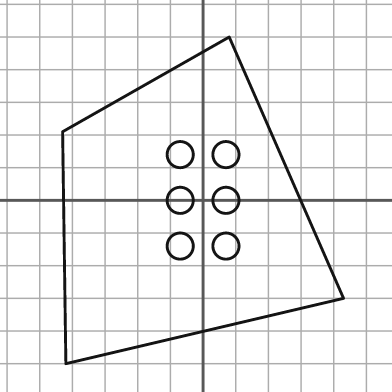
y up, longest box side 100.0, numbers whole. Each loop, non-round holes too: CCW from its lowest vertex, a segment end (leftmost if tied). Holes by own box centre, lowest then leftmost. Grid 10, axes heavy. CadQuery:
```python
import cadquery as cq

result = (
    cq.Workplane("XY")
    .moveTo(-42.0, -50.0)
    .lineTo(43.0, -30.0)
    .lineTo(8.0, 50.0)
    .lineTo(-43.0, 21.0)
    .close()
    .moveTo(-7.0, -14.0)
    .circle(4.0)
    .moveTo(7.0, -14.0)
    .circle(4.0)
    .moveTo(-7.0, 0.0)
    .circle(4.0)
    .moveTo(7.0, 0.0)
    .circle(4.0)
    .moveTo(-7.0, 14.0)
    .circle(4.0)
    .moveTo(7.0, 14.0)
    .circle(4.0)
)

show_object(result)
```